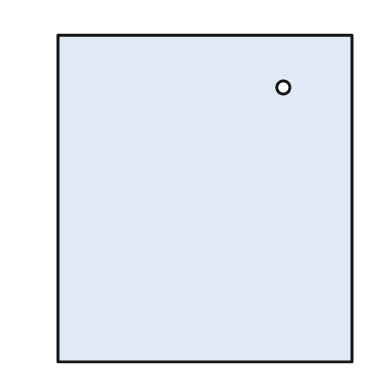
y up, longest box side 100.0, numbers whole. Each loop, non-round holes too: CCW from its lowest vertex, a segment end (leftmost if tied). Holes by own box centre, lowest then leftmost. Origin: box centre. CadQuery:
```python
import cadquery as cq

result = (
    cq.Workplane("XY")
    .moveTo(-45.0, -50.0)
    .lineTo(45.0, -50.0)
    .lineTo(45.0, 50.0)
    .lineTo(-45.0, 50.0)
    .close()
    .moveTo(24.0, 34.0)
    .circle(2.0)
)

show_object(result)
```